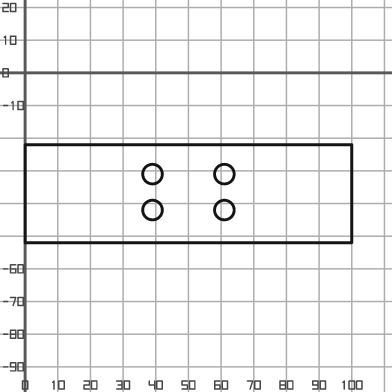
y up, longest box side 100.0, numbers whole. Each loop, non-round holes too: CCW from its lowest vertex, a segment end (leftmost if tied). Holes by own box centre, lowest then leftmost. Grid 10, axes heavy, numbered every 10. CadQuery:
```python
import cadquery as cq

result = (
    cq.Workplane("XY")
    .moveTo(0.0, -52.0)
    .lineTo(100.0, -52.0)
    .lineTo(100.0, -22.0)
    .lineTo(0.0, -22.0)
    .close()
    .moveTo(39.0, -42.0)
    .circle(3.0)
    .moveTo(61.0, -42.0)
    .circle(3.0)
    .moveTo(39.0, -31.0)
    .circle(3.0)
    .moveTo(61.0, -31.0)
    .circle(3.0)
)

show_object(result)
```